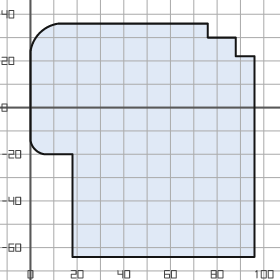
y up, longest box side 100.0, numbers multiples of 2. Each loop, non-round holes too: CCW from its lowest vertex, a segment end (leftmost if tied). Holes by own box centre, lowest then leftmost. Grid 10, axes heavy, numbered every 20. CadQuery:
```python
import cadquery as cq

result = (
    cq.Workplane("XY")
    .moveTo(18.0, -64.0)
    .lineTo(96.0, -64.0)
    .lineTo(96.0, 22.0)
    .lineTo(88.0, 22.0)
    .lineTo(88.0, 30.0)
    .lineTo(76.0, 30.0)
    .lineTo(76.0, 36.0)
    .lineTo(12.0, 36.0)
    .threePointArc((4.0, 32.0), (0.0, 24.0))
    .lineTo(0.0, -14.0)
    .threePointArc((2.0, -18.0), (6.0, -20.0))
    .lineTo(18.0, -20.0)
    .close()
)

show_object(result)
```